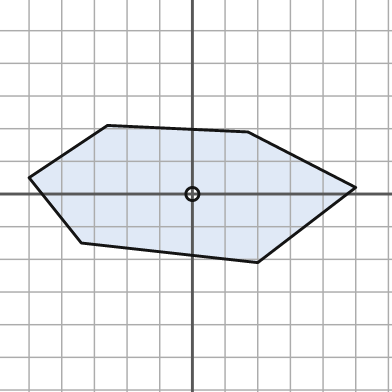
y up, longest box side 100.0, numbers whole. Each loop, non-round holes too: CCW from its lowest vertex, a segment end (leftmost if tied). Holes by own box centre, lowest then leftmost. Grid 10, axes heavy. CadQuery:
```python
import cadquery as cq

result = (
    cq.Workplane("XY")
    .moveTo(20.0, -21.0)
    .lineTo(50.0, 2.0)
    .lineTo(17.0, 19.0)
    .lineTo(-26.0, 21.0)
    .lineTo(-50.0, 5.0)
    .lineTo(-34.0, -15.0)
    .close()
    .moveTo(0.0, 0.0)
    .circle(2.0)
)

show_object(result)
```